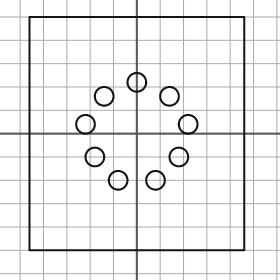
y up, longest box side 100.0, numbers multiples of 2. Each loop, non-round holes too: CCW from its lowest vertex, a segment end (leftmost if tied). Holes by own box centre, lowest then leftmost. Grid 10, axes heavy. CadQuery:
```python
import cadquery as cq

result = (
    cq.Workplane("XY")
    .moveTo(-46.0, -50.0)
    .lineTo(46.0, -50.0)
    .lineTo(46.0, 50.0)
    .lineTo(-46.0, 50.0)
    .close()
    .moveTo(-8.0, -20.0)
    .circle(4.0)
    .moveTo(8.0, -20.0)
    .circle(4.0)
    .moveTo(-18.0, -10.0)
    .circle(4.0)
    .moveTo(18.0, -10.0)
    .circle(4.0)
    .moveTo(-22.0, 4.0)
    .circle(4.0)
    .moveTo(22.0, 4.0)
    .circle(4.0)
    .moveTo(-14.0, 16.0)
    .circle(4.0)
    .moveTo(14.0, 16.0)
    .circle(4.0)
    .moveTo(0.0, 22.0)
    .circle(4.0)
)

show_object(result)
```